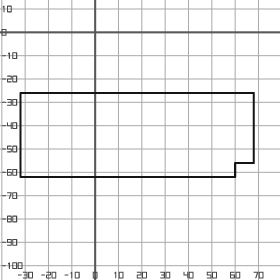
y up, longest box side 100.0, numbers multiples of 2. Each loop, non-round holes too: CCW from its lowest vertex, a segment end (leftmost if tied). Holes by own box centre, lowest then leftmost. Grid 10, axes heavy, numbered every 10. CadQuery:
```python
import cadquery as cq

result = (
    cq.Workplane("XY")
    .moveTo(-32.0, -62.0)
    .lineTo(60.0, -62.0)
    .lineTo(60.0, -56.0)
    .lineTo(68.0, -56.0)
    .lineTo(68.0, -26.0)
    .lineTo(-32.0, -26.0)
    .close()
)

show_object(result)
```